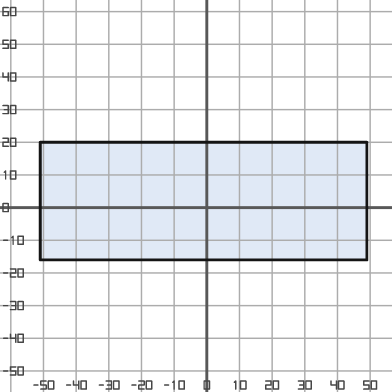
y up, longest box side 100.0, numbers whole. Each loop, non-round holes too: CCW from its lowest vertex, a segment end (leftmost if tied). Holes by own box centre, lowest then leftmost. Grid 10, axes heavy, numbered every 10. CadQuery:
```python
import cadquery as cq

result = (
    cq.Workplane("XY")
    .moveTo(-51.0, -16.0)
    .lineTo(49.0, -16.0)
    .lineTo(49.0, 20.0)
    .lineTo(-51.0, 20.0)
    .close()
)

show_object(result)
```